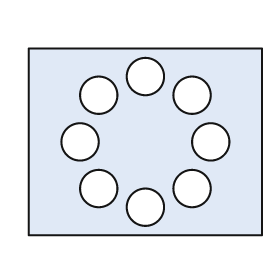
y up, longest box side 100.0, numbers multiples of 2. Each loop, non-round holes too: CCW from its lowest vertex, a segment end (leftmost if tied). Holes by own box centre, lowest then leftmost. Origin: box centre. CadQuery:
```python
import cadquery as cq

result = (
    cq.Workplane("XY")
    .moveTo(-50.0, -40.0)
    .lineTo(50.0, -40.0)
    .lineTo(50.0, 40.0)
    .lineTo(-50.0, 40.0)
    .close()
    .moveTo(0.0, -28.0)
    .circle(8.0)
    .moveTo(-20.0, -20.0)
    .circle(8.0)
    .moveTo(20.0, -20.0)
    .circle(8.0)
    .moveTo(-28.0, 0.0)
    .circle(8.0)
    .moveTo(28.0, 0.0)
    .circle(8.0)
    .moveTo(-20.0, 20.0)
    .circle(8.0)
    .moveTo(20.0, 20.0)
    .circle(8.0)
    .moveTo(0.0, 28.0)
    .circle(8.0)
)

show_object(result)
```